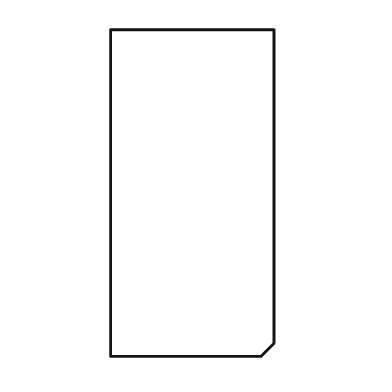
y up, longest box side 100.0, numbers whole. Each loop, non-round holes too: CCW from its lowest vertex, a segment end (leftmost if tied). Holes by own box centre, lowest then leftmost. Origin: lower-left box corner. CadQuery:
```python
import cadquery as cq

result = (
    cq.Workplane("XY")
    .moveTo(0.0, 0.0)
    .lineTo(46.0, 0.0)
    .lineTo(50.0, 4.0)
    .lineTo(50.0, 100.0)
    .lineTo(0.0, 100.0)
    .close()
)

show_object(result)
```